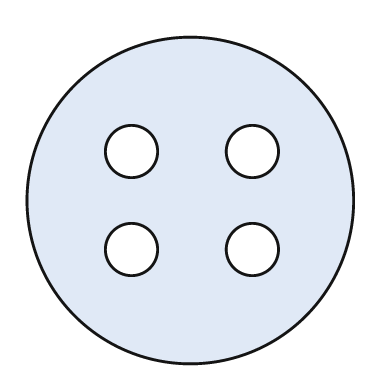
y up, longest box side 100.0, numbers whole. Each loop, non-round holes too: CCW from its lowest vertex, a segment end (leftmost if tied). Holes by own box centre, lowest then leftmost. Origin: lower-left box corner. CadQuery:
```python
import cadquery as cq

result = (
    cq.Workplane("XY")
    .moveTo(50.0, 50.0)
    .circle(50.0)
    .moveTo(32.0, 35.0)
    .circle(8.0)
    .moveTo(69.0, 35.0)
    .circle(8.0)
    .moveTo(32.0, 65.0)
    .circle(8.0)
    .moveTo(69.0, 65.0)
    .circle(8.0)
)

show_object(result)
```